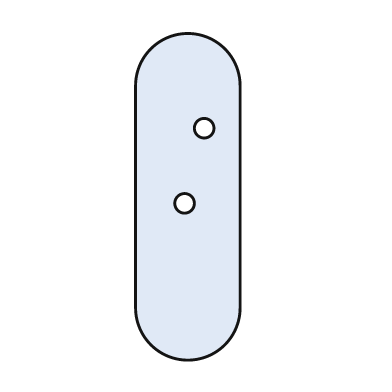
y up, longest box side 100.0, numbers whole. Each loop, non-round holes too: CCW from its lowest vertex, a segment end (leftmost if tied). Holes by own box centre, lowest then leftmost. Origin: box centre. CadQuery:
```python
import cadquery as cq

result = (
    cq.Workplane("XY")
    .moveTo(-16.0, -34.0)
    .threePointArc((0.0, -50.0), (16.0, -34.0))
    .lineTo(16.0, 34.0)
    .threePointArc((0.0, 50.0), (-16.0, 34.0))
    .close()
    .moveTo(-1.0, -2.0)
    .circle(3.0)
    .moveTo(5.0, 21.0)
    .circle(3.0)
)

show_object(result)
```